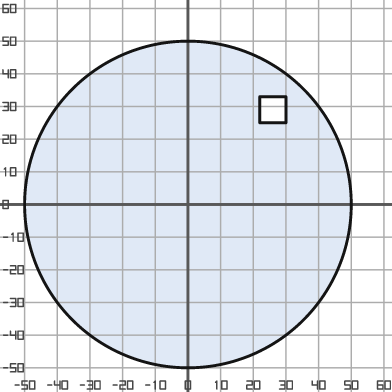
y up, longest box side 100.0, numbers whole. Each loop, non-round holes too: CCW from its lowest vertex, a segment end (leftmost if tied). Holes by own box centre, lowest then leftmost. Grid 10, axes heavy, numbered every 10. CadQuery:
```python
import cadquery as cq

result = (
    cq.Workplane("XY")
    .moveTo(0.0, 0.0)
    .circle(50.0)
    .moveTo(22.0, 25.0)
    .lineTo(30.0, 25.0)
    .lineTo(30.0, 33.0)
    .lineTo(22.0, 33.0)
    .close()
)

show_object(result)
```